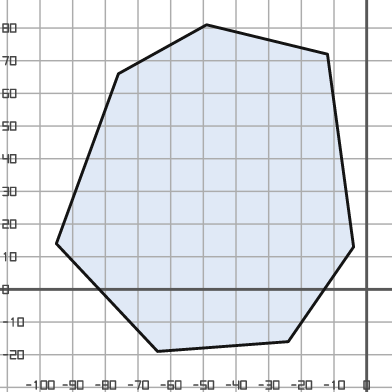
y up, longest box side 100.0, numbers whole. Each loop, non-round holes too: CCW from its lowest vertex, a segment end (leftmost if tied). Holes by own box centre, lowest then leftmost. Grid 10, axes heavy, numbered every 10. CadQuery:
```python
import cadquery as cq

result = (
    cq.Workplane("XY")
    .moveTo(-64.0, -19.0)
    .lineTo(-24.0, -16.0)
    .lineTo(-4.0, 13.0)
    .lineTo(-12.0, 72.0)
    .lineTo(-49.0, 81.0)
    .lineTo(-76.0, 66.0)
    .lineTo(-95.0, 14.0)
    .close()
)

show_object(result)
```